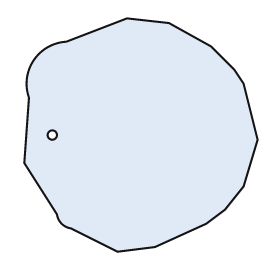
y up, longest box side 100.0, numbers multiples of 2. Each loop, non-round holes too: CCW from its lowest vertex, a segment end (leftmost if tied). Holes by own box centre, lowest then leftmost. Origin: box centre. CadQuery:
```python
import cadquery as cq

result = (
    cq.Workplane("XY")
    .moveTo(-10.0, -50.0)
    .lineTo(6.0, -48.0)
    .lineTo(28.0, -38.0)
    .lineTo(36.0, -32.0)
    .lineTo(44.0, -22.0)
    .lineTo(50.0, -2.0)
    .lineTo(44.0, 22.0)
    .lineTo(40.0, 28.0)
    .lineTo(30.0, 38.0)
    .lineTo(12.0, 48.0)
    .lineTo(-6.0, 50.0)
    .lineTo(-32.0, 40.0)
    .threePointArc((-46.0, 32.0), (-48.0, 16.0))
    .lineTo(-50.0, -12.0)
    .lineTo(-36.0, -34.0)
    .threePointArc((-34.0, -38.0), (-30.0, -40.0))
    .close()
    .moveTo(-38.0, 0.0)
    .circle(2.0)
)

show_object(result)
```